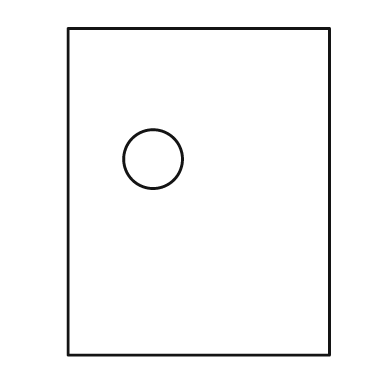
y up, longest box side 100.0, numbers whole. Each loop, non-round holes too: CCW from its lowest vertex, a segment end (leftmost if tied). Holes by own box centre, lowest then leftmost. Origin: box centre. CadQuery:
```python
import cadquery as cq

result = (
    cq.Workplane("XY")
    .moveTo(-40.0, -50.0)
    .lineTo(40.0, -50.0)
    .lineTo(40.0, 50.0)
    .lineTo(-40.0, 50.0)
    .close()
    .moveTo(-14.0, 10.0)
    .circle(9.0)
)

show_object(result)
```